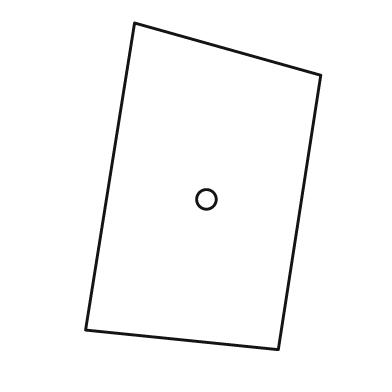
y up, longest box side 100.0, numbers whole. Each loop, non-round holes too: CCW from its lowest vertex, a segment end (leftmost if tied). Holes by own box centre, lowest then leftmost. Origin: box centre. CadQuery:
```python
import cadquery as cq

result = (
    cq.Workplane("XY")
    .moveTo(23.0, -50.0)
    .lineTo(36.0, 34.0)
    .lineTo(-21.0, 50.0)
    .lineTo(-36.0, -44.0)
    .close()
    .moveTo(1.0, -4.0)
    .circle(3.0)
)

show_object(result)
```